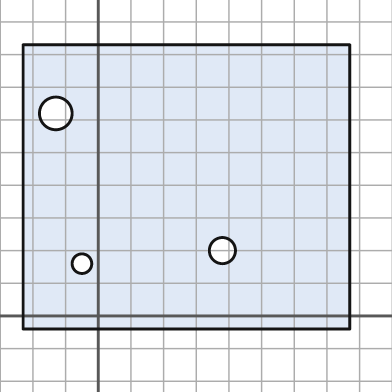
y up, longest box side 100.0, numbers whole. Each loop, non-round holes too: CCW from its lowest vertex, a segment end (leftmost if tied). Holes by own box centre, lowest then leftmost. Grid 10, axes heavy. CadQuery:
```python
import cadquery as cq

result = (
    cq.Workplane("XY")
    .moveTo(-23.0, -4.0)
    .lineTo(77.0, -4.0)
    .lineTo(77.0, 83.0)
    .lineTo(-23.0, 83.0)
    .close()
    .moveTo(-5.0, 16.0)
    .circle(3.0)
    .moveTo(38.0, 20.0)
    .circle(4.0)
    .moveTo(-13.0, 62.0)
    .circle(5.0)
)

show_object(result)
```